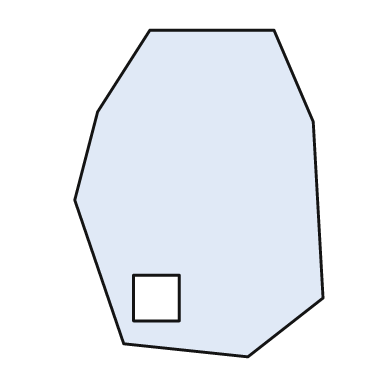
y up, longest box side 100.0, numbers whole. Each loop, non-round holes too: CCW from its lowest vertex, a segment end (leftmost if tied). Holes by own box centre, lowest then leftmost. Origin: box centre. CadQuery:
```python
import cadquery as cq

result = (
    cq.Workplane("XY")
    .moveTo(15.0, -50.0)
    .lineTo(38.0, -32.0)
    .lineTo(35.0, 22.0)
    .lineTo(23.0, 50.0)
    .lineTo(-15.0, 50.0)
    .lineTo(-31.0, 25.0)
    .lineTo(-38.0, -2.0)
    .lineTo(-23.0, -46.0)
    .close()
    .moveTo(-20.0, -39.0)
    .lineTo(-6.0, -39.0)
    .lineTo(-6.0, -25.0)
    .lineTo(-20.0, -25.0)
    .close()
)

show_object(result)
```